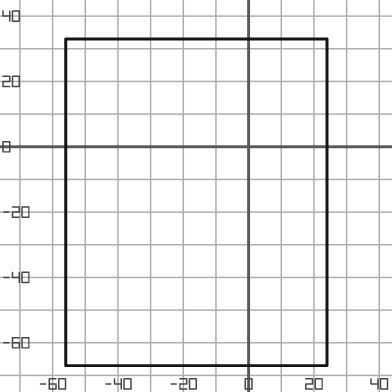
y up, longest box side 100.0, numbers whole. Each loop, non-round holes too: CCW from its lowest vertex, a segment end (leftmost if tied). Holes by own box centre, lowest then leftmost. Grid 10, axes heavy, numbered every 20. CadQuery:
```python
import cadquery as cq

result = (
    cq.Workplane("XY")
    .moveTo(-56.0, -67.0)
    .lineTo(24.0, -67.0)
    .lineTo(24.0, 33.0)
    .lineTo(-56.0, 33.0)
    .close()
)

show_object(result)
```